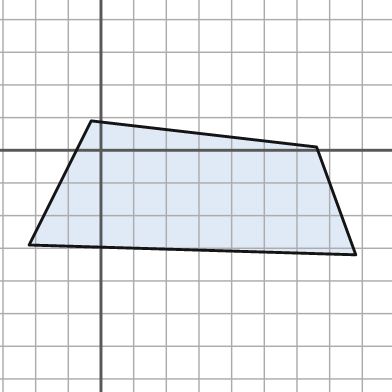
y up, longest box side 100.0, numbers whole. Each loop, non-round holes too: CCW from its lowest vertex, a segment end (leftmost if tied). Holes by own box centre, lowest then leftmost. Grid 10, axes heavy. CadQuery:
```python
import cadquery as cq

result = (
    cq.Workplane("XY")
    .moveTo(78.0, -32.0)
    .lineTo(66.0, 1.0)
    .lineTo(-3.0, 9.0)
    .lineTo(-22.0, -29.0)
    .close()
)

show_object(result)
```